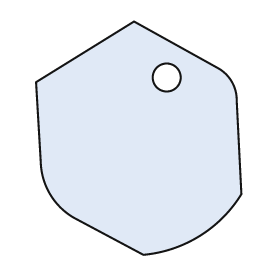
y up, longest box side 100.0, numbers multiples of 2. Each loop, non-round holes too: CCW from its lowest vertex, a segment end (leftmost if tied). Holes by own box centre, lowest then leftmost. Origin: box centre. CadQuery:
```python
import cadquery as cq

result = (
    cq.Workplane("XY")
    .moveTo(2.0, -50.0)
    .threePointArc((26.0, -42.0), (44.0, -24.0))
    .lineTo(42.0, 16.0)
    .threePointArc((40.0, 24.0), (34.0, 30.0))
    .lineTo(-2.0, 50.0)
    .lineTo(-44.0, 24.0)
    .lineTo(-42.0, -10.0)
    .threePointArc((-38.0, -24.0), (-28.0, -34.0))
    .close()
    .moveTo(12.0, 26.0)
    .circle(6.0)
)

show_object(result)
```